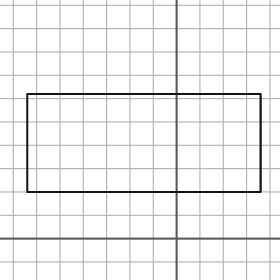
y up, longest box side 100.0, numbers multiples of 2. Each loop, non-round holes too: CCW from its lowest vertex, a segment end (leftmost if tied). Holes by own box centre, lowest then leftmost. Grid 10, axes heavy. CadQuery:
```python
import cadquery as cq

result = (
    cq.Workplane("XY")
    .moveTo(-64.0, 20.0)
    .lineTo(36.0, 20.0)
    .lineTo(36.0, 62.0)
    .lineTo(-64.0, 62.0)
    .close()
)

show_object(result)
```